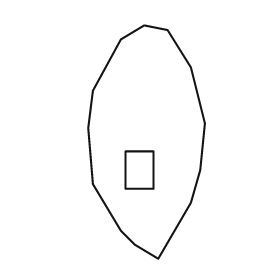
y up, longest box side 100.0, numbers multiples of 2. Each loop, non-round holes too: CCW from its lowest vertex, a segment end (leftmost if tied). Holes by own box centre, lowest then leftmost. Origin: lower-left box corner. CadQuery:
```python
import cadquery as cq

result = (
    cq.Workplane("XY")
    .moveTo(30.0, 0.0)
    .lineTo(44.0, 24.0)
    .lineTo(48.0, 38.0)
    .lineTo(50.0, 58.0)
    .lineTo(44.0, 82.0)
    .lineTo(34.0, 98.0)
    .lineTo(24.0, 100.0)
    .lineTo(14.0, 94.0)
    .lineTo(2.0, 72.0)
    .lineTo(0.0, 56.0)
    .lineTo(2.0, 32.0)
    .lineTo(14.0, 12.0)
    .lineTo(20.0, 6.0)
    .close()
    .moveTo(16.0, 30.0)
    .lineTo(28.0, 30.0)
    .lineTo(28.0, 46.0)
    .lineTo(16.0, 46.0)
    .close()
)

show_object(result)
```